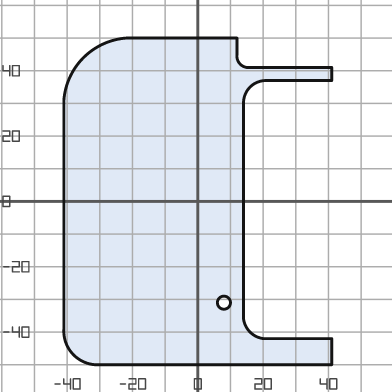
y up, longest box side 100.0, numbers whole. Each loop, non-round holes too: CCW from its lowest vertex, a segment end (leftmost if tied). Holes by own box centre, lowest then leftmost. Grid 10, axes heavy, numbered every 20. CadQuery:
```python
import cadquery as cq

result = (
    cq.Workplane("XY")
    .moveTo(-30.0, -50.0)
    .lineTo(41.0, -50.0)
    .lineTo(41.0, -42.0)
    .lineTo(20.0, -42.0)
    .threePointArc((16.0, -40.0), (14.0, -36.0))
    .lineTo(14.0, 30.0)
    .threePointArc((16.0, 35.0), (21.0, 37.0))
    .lineTo(41.0, 37.0)
    .lineTo(41.0, 41.0)
    .lineTo(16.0, 41.0)
    .threePointArc((13.0, 42.0), (12.0, 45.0))
    .lineTo(12.0, 50.0)
    .lineTo(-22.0, 50.0)
    .threePointArc((-35.0, 44.0), (-41.0, 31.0))
    .lineTo(-41.0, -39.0)
    .threePointArc((-38.0, -47.0), (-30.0, -50.0))
    .close()
    .moveTo(8.0, -31.0)
    .circle(2.0)
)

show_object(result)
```